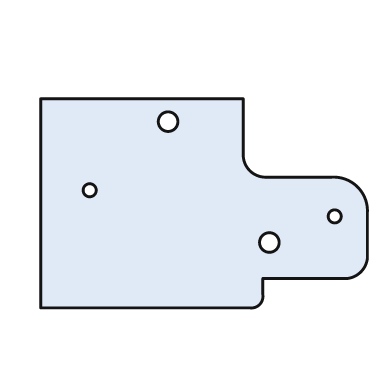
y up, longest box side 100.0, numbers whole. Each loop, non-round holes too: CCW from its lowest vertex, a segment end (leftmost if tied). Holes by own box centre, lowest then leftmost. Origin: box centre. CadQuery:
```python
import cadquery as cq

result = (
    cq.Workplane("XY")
    .moveTo(-50.0, -32.0)
    .lineTo(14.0, -32.0)
    .threePointArc((17.0, -31.0), (18.0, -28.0))
    .lineTo(18.0, -23.0)
    .lineTo(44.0, -23.0)
    .threePointArc((48.0, -21.0), (50.0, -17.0))
    .lineTo(50.0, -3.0)
    .threePointArc((47.0, 5.0), (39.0, 8.0))
    .lineTo(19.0, 8.0)
    .threePointArc((14.0, 10.0), (12.0, 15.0))
    .lineTo(12.0, 32.0)
    .lineTo(-50.0, 32.0)
    .close()
    .moveTo(20.0, -12.0)
    .circle(3.0)
    .moveTo(40.0, -4.0)
    .circle(2.0)
    .moveTo(-35.0, 4.0)
    .circle(2.0)
    .moveTo(-11.0, 25.0)
    .circle(3.0)
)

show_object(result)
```